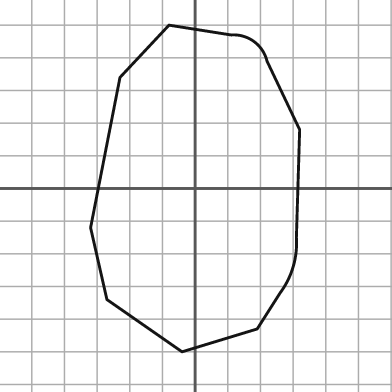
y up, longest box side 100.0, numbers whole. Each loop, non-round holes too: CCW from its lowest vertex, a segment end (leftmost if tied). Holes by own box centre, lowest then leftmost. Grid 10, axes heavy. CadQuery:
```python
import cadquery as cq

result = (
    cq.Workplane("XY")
    .moveTo(-4.0, -50.0)
    .lineTo(19.0, -43.0)
    .lineTo(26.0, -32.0)
    .threePointArc((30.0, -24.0), (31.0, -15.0))
    .lineTo(32.0, 18.0)
    .lineTo(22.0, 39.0)
    .threePointArc((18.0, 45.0), (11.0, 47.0))
    .lineTo(-8.0, 50.0)
    .lineTo(-23.0, 34.0)
    .lineTo(-32.0, -12.0)
    .lineTo(-27.0, -34.0)
    .close()
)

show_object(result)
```